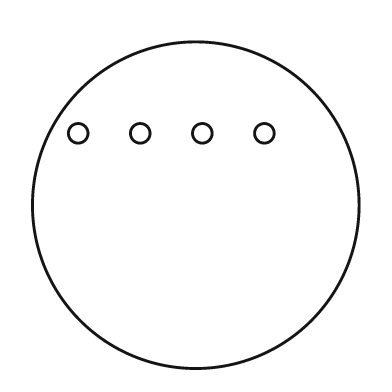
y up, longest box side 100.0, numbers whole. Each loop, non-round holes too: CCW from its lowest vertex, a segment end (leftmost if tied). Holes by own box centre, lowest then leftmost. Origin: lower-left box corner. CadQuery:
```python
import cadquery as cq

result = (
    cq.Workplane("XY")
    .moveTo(50.0, 50.0)
    .circle(50.0)
    .moveTo(14.0, 72.0)
    .circle(3.0)
    .moveTo(33.0, 72.0)
    .circle(3.0)
    .moveTo(52.0, 72.0)
    .circle(3.0)
    .moveTo(71.0, 72.0)
    .circle(3.0)
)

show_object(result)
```